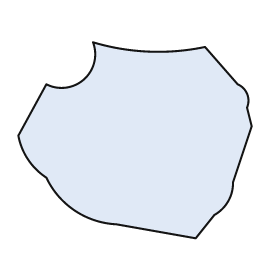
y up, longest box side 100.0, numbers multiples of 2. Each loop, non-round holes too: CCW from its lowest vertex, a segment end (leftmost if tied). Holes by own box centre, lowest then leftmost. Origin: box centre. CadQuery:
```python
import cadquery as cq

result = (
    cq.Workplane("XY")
    .moveTo(26.0, -42.0)
    .lineTo(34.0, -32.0)
    .threePointArc((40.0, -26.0), (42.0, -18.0))
    .lineTo(50.0, 6.0)
    .lineTo(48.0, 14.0)
    .threePointArc((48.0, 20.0), (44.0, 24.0))
    .lineTo(30.0, 40.0)
    .threePointArc((6.0, 38.0), (-18.0, 42.0))
    .threePointArc((-22.0, 26.0), (-38.0, 24.0))
    .lineTo(-50.0, 2.0)
    .threePointArc((-46.0, -8.0), (-38.0, -16.0))
    .threePointArc((-26.0, -30.0), (-8.0, -36.0))
    .close()
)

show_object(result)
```